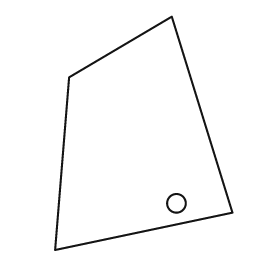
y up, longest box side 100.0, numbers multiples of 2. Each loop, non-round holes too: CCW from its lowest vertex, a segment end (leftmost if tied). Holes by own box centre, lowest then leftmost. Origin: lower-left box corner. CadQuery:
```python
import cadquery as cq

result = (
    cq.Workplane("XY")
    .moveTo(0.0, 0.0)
    .lineTo(76.0, 16.0)
    .lineTo(50.0, 100.0)
    .lineTo(6.0, 74.0)
    .close()
    .moveTo(52.0, 20.0)
    .circle(4.0)
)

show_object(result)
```